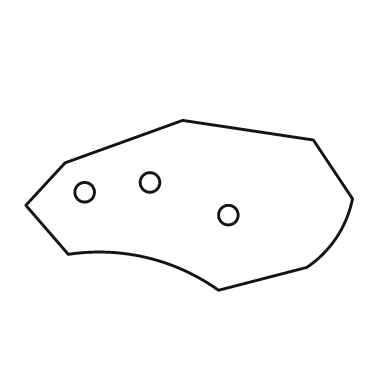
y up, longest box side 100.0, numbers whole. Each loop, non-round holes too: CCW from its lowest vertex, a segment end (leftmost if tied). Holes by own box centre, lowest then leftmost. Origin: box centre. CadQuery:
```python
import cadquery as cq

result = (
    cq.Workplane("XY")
    .moveTo(9.0, -26.0)
    .lineTo(36.0, -19.0)
    .threePointArc((45.0, -10.0), (50.0, 2.0))
    .lineTo(38.0, 20.0)
    .lineTo(-2.0, 26.0)
    .lineTo(-38.0, 13.0)
    .lineTo(-50.0, 0.0)
    .lineTo(-37.0, -15.0)
    .threePointArc((-13.0, -16.0), (9.0, -26.0))
    .close()
    .moveTo(12.0, -3.0)
    .circle(3.0)
    .moveTo(-32.0, 4.0)
    .circle(3.0)
    .moveTo(-12.0, 7.0)
    .circle(3.0)
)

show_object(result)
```